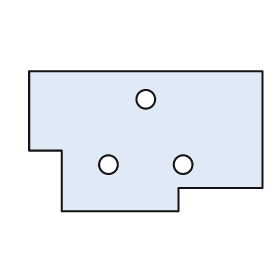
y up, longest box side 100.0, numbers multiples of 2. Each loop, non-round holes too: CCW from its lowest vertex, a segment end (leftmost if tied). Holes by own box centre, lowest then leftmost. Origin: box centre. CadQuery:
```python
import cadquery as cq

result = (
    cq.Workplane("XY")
    .moveTo(-36.0, -30.0)
    .lineTo(14.0, -30.0)
    .lineTo(14.0, -20.0)
    .lineTo(50.0, -20.0)
    .lineTo(50.0, 30.0)
    .lineTo(-50.0, 30.0)
    .lineTo(-50.0, -4.0)
    .lineTo(-36.0, -4.0)
    .close()
    .moveTo(-16.0, -10.0)
    .circle(4.0)
    .moveTo(16.0, -10.0)
    .circle(4.0)
    .moveTo(0.0, 18.0)
    .circle(4.0)
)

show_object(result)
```